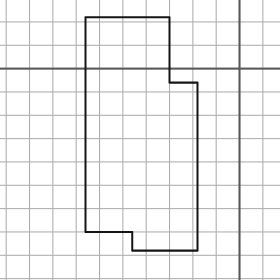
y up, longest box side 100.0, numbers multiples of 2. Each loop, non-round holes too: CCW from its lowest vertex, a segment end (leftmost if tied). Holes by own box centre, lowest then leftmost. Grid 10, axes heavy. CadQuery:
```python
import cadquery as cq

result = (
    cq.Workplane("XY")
    .moveTo(-46.0, -78.0)
    .lineTo(-18.0, -78.0)
    .lineTo(-18.0, -6.0)
    .lineTo(-30.0, -6.0)
    .lineTo(-30.0, 22.0)
    .lineTo(-66.0, 22.0)
    .lineTo(-66.0, -70.0)
    .lineTo(-46.0, -70.0)
    .close()
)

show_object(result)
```